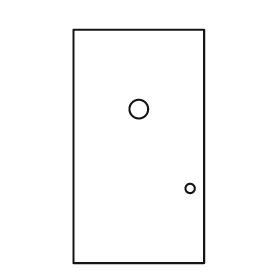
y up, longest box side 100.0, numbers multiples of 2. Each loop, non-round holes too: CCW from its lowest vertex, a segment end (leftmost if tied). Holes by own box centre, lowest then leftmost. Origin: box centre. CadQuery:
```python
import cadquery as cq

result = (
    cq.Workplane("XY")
    .moveTo(-28.0, -50.0)
    .lineTo(28.0, -50.0)
    .lineTo(28.0, 50.0)
    .lineTo(-28.0, 50.0)
    .close()
    .moveTo(22.0, -18.0)
    .circle(2.0)
    .moveTo(0.0, 16.0)
    .circle(4.0)
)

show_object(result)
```